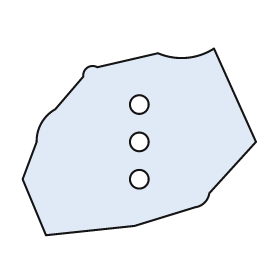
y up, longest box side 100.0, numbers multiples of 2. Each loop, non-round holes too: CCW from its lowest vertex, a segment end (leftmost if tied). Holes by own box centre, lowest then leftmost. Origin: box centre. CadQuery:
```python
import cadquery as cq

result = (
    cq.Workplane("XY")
    .moveTo(-40.0, -40.0)
    .lineTo(-2.0, -36.0)
    .lineTo(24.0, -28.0)
    .threePointArc((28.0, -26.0), (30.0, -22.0))
    .lineTo(50.0, 0.0)
    .lineTo(32.0, 40.0)
    .threePointArc((20.0, 36.0), (8.0, 38.0))
    .lineTo(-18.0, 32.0)
    .threePointArc((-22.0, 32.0), (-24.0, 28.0))
    .lineTo(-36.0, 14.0)
    .threePointArc((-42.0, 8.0), (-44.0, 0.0))
    .lineTo(-50.0, -16.0)
    .close()
    .moveTo(0.0, -16.0)
    .circle(4.0)
    .moveTo(0.0, 0.0)
    .circle(4.0)
    .moveTo(0.0, 16.0)
    .circle(4.0)
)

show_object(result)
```